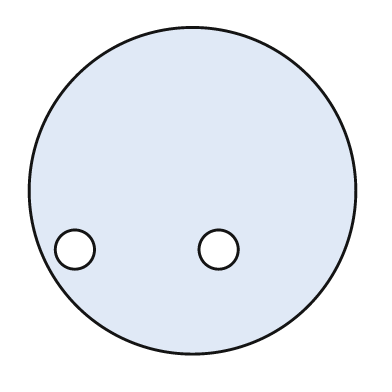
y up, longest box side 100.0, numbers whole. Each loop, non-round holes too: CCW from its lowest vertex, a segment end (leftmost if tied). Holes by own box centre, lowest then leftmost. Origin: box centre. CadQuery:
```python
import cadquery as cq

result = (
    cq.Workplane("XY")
    .moveTo(0.0, 0.0)
    .circle(50.0)
    .moveTo(-36.0, -18.0)
    .circle(6.0)
    .moveTo(8.0, -18.0)
    .circle(6.0)
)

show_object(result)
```